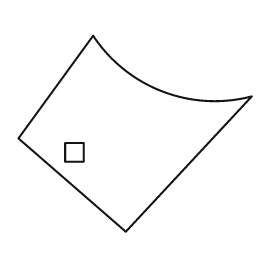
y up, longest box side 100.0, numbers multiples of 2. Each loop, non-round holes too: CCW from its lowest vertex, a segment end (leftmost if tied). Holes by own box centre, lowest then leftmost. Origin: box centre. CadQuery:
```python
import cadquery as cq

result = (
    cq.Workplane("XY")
    .moveTo(-4.0, -42.0)
    .lineTo(50.0, 16.0)
    .threePointArc((12.0, 18.0), (-18.0, 42.0))
    .lineTo(-50.0, -2.0)
    .close()
    .moveTo(-30.0, -12.0)
    .lineTo(-22.0, -12.0)
    .lineTo(-22.0, -4.0)
    .lineTo(-30.0, -4.0)
    .close()
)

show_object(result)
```